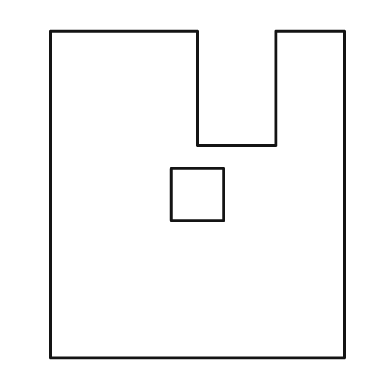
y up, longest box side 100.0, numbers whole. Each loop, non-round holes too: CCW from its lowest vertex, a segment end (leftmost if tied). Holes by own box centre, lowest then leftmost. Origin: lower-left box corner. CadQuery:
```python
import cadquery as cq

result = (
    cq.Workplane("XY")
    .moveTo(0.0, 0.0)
    .lineTo(90.0, 0.0)
    .lineTo(90.0, 100.0)
    .lineTo(69.0, 100.0)
    .lineTo(69.0, 65.0)
    .lineTo(45.0, 65.0)
    .lineTo(45.0, 100.0)
    .lineTo(0.0, 100.0)
    .close()
    .moveTo(37.0, 42.0)
    .lineTo(53.0, 42.0)
    .lineTo(53.0, 58.0)
    .lineTo(37.0, 58.0)
    .close()
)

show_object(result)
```